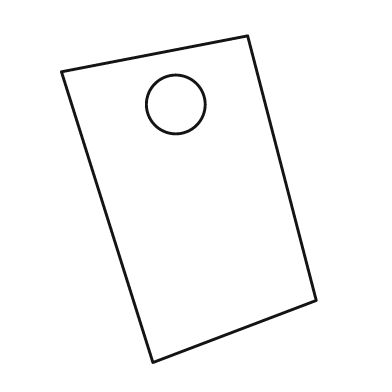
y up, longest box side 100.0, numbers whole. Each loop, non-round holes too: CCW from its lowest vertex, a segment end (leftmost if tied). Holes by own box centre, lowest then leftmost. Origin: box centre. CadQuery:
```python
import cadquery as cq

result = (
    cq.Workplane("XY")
    .moveTo(-11.0, -50.0)
    .lineTo(39.0, -31.0)
    .lineTo(18.0, 50.0)
    .lineTo(-39.0, 39.0)
    .close()
    .moveTo(-4.0, 29.0)
    .circle(9.0)
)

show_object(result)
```